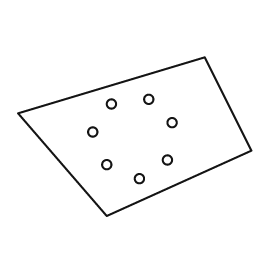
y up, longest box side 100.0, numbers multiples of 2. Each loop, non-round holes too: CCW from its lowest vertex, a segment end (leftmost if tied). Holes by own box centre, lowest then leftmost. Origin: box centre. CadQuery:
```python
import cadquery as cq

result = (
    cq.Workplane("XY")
    .moveTo(-12.0, -34.0)
    .lineTo(50.0, -6.0)
    .lineTo(30.0, 34.0)
    .lineTo(-50.0, 10.0)
    .close()
    .moveTo(2.0, -18.0)
    .circle(2.0)
    .moveTo(-12.0, -12.0)
    .circle(2.0)
    .moveTo(14.0, -10.0)
    .circle(2.0)
    .moveTo(-18.0, 2.0)
    .circle(2.0)
    .moveTo(16.0, 6.0)
    .circle(2.0)
    .moveTo(-10.0, 14.0)
    .circle(2.0)
    .moveTo(6.0, 16.0)
    .circle(2.0)
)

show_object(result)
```